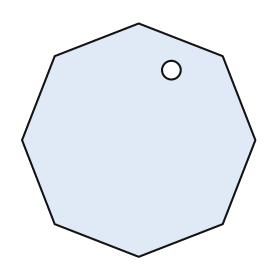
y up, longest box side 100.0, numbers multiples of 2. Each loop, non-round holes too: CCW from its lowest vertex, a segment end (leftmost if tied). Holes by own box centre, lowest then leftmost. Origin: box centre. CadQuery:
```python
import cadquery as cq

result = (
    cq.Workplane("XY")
    .moveTo(0.0, -50.0)
    .lineTo(36.0, -36.0)
    .lineTo(50.0, 0.0)
    .lineTo(36.0, 36.0)
    .lineTo(0.0, 50.0)
    .lineTo(-36.0, 36.0)
    .lineTo(-50.0, 0.0)
    .lineTo(-36.0, -36.0)
    .close()
    .moveTo(14.0, 30.0)
    .circle(4.0)
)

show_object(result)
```